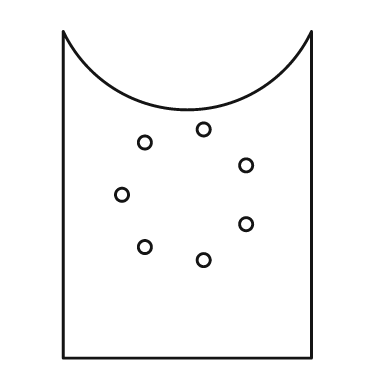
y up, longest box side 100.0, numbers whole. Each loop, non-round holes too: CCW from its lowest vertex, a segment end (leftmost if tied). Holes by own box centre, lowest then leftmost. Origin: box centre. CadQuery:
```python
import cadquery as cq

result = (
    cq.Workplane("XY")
    .moveTo(-38.0, -50.0)
    .lineTo(38.0, -50.0)
    .lineTo(38.0, 50.0)
    .threePointArc((0.0, 26.0), (-38.0, 50.0))
    .close()
    .moveTo(5.0, -20.0)
    .circle(2.0)
    .moveTo(-13.0, -16.0)
    .circle(2.0)
    .moveTo(18.0, -9.0)
    .circle(2.0)
    .moveTo(-20.0, 0.0)
    .circle(2.0)
    .moveTo(18.0, 9.0)
    .circle(2.0)
    .moveTo(-13.0, 16.0)
    .circle(2.0)
    .moveTo(5.0, 20.0)
    .circle(2.0)
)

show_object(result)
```